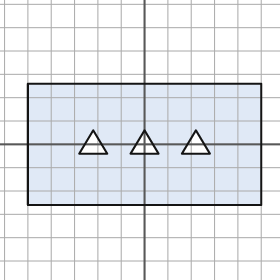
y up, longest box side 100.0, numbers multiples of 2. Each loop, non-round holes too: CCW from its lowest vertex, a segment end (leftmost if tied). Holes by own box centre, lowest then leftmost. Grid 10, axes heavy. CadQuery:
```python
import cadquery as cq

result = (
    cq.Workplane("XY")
    .moveTo(-50.0, -26.0)
    .lineTo(50.0, -26.0)
    .lineTo(50.0, 26.0)
    .lineTo(-50.0, 26.0)
    .close()
    .moveTo(-28.0, -4.0)
    .lineTo(-16.0, -4.0)
    .lineTo(-22.0, 6.0)
    .close()
    .moveTo(-6.0, -4.0)
    .lineTo(6.0, -4.0)
    .lineTo(0.0, 6.0)
    .close()
    .moveTo(16.0, -4.0)
    .lineTo(28.0, -4.0)
    .lineTo(22.0, 6.0)
    .close()
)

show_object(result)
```